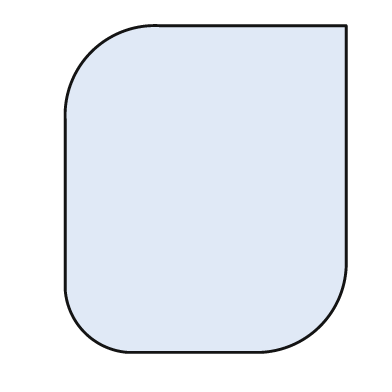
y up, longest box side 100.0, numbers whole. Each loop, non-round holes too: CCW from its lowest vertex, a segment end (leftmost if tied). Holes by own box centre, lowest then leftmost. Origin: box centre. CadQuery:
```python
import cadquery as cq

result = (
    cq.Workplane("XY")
    .moveTo(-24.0, -50.0)
    .lineTo(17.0, -50.0)
    .threePointArc((35.0, -42.0), (43.0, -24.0))
    .lineTo(43.0, 50.0)
    .lineTo(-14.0, 50.0)
    .threePointArc((-35.0, 42.0), (-43.0, 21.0))
    .lineTo(-43.0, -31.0)
    .threePointArc((-37.0, -44.0), (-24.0, -50.0))
    .close()
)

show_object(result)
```